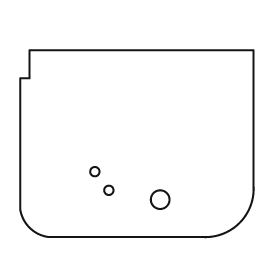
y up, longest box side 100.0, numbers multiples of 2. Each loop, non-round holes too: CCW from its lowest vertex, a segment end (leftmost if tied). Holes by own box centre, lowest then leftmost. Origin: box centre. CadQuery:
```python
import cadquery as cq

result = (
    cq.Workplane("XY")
    .moveTo(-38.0, -40.0)
    .lineTo(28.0, -40.0)
    .threePointArc((44.0, -34.0), (50.0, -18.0))
    .lineTo(50.0, 40.0)
    .lineTo(-46.0, 40.0)
    .lineTo(-46.0, 28.0)
    .lineTo(-50.0, 28.0)
    .lineTo(-50.0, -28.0)
    .threePointArc((-46.0, -36.0), (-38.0, -40.0))
    .close()
    .moveTo(10.0, -24.0)
    .circle(4.0)
    .moveTo(-12.0, -20.0)
    .circle(2.0)
    .moveTo(-18.0, -12.0)
    .circle(2.0)
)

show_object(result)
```